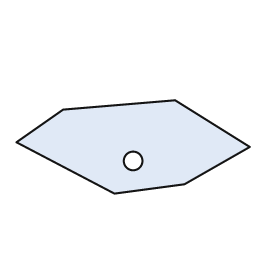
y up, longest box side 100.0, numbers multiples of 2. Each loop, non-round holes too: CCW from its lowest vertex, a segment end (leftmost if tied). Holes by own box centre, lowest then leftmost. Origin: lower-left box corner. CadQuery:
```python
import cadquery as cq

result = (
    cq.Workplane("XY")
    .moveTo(42.0, 0.0)
    .lineTo(72.0, 4.0)
    .lineTo(100.0, 20.0)
    .lineTo(68.0, 40.0)
    .lineTo(20.0, 36.0)
    .lineTo(0.0, 22.0)
    .close()
    .moveTo(50.0, 14.0)
    .circle(4.0)
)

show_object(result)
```